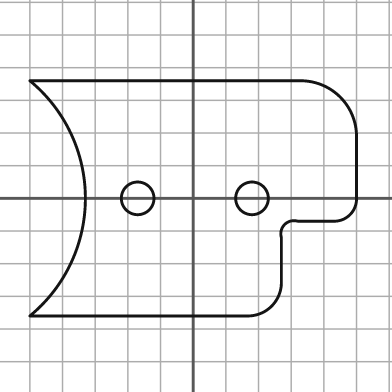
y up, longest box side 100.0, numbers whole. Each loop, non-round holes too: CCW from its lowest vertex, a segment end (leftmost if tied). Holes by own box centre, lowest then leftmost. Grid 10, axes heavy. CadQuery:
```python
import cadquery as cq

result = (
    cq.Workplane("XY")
    .moveTo(-50.0, -36.0)
    .lineTo(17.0, -36.0)
    .threePointArc((24.0, -33.0), (27.0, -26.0))
    .lineTo(27.0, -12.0)
    .threePointArc((28.0, -8.0), (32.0, -7.0))
    .lineTo(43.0, -7.0)
    .threePointArc((48.0, -5.0), (50.0, 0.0))
    .lineTo(50.0, 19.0)
    .threePointArc((45.0, 31.0), (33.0, 36.0))
    .lineTo(-50.0, 36.0)
    .threePointArc((-33.0, 0.0), (-50.0, -36.0))
    .close()
    .moveTo(-17.0, 0.0)
    .circle(5.0)
    .moveTo(18.0, 0.0)
    .circle(5.0)
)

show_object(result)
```